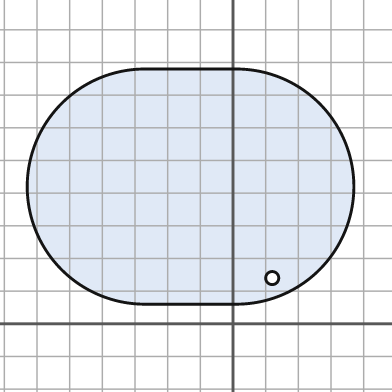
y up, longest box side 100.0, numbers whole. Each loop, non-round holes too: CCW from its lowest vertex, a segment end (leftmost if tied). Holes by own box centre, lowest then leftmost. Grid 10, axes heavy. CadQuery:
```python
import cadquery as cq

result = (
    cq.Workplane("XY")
    .moveTo(-27.0, 6.0)
    .lineTo(1.0, 6.0)
    .threePointArc((37.0, 42.0), (1.0, 78.0))
    .lineTo(-27.0, 78.0)
    .threePointArc((-63.0, 42.0), (-27.0, 6.0))
    .close()
    .moveTo(12.0, 14.0)
    .circle(2.0)
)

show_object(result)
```